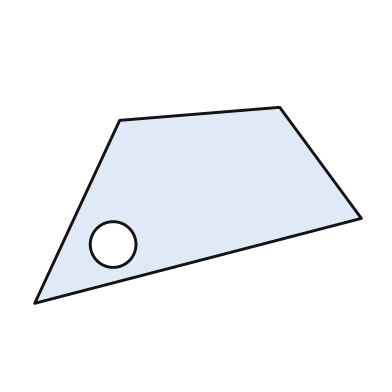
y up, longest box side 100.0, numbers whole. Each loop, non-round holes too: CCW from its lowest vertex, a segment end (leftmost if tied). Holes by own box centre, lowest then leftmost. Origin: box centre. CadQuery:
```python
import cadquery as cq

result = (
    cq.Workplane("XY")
    .moveTo(-50.0, -30.0)
    .lineTo(50.0, -4.0)
    .lineTo(25.0, 30.0)
    .lineTo(-24.0, 26.0)
    .close()
    .moveTo(-26.0, -12.0)
    .circle(7.0)
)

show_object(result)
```